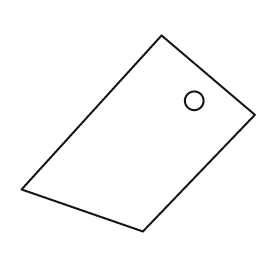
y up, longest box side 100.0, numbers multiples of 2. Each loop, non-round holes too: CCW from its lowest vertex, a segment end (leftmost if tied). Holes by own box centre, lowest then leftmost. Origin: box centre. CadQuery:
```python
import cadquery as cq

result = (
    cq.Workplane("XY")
    .moveTo(2.0, -42.0)
    .lineTo(50.0, 8.0)
    .lineTo(10.0, 42.0)
    .lineTo(-50.0, -24.0)
    .close()
    .moveTo(24.0, 14.0)
    .circle(4.0)
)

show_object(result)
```